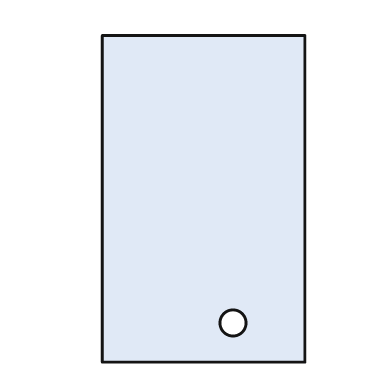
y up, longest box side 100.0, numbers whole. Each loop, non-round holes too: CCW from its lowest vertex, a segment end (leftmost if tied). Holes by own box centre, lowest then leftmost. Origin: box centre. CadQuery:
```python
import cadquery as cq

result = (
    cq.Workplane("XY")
    .moveTo(-31.0, -50.0)
    .lineTo(31.0, -50.0)
    .lineTo(31.0, 50.0)
    .lineTo(-31.0, 50.0)
    .close()
    .moveTo(9.0, -38.0)
    .circle(4.0)
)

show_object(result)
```